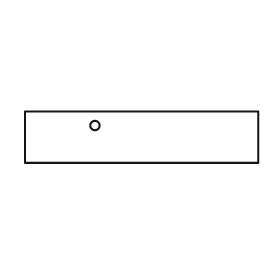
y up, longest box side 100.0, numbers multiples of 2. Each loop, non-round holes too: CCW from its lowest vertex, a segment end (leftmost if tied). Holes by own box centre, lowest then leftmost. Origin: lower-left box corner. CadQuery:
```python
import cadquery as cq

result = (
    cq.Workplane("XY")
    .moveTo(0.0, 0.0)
    .lineTo(100.0, 0.0)
    .lineTo(100.0, 22.0)
    .lineTo(0.0, 22.0)
    .close()
    .moveTo(30.0, 16.0)
    .circle(2.0)
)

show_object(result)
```